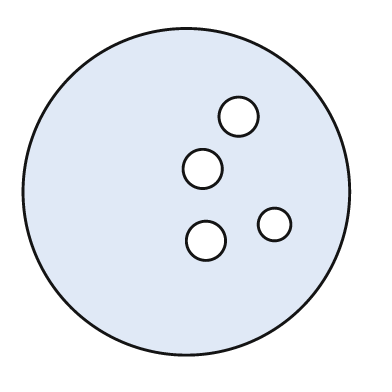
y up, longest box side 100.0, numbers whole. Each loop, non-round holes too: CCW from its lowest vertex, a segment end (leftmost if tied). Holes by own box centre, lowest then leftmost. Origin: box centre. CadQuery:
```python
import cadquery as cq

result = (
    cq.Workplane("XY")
    .moveTo(0.0, 0.0)
    .circle(50.0)
    .moveTo(6.0, -15.0)
    .circle(6.0)
    .moveTo(27.0, -10.0)
    .circle(5.0)
    .moveTo(5.0, 7.0)
    .circle(6.0)
    .moveTo(16.0, 23.0)
    .circle(6.0)
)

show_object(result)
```